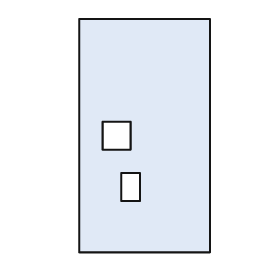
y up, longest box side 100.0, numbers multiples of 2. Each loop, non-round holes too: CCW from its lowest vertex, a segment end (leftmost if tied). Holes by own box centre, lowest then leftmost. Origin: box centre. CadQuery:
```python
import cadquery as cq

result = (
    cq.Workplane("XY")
    .moveTo(-28.0, -50.0)
    .lineTo(28.0, -50.0)
    .lineTo(28.0, 50.0)
    .lineTo(-28.0, 50.0)
    .close()
    .moveTo(-10.0, -28.0)
    .lineTo(-2.0, -28.0)
    .lineTo(-2.0, -16.0)
    .lineTo(-10.0, -16.0)
    .close()
    .moveTo(-18.0, -6.0)
    .lineTo(-6.0, -6.0)
    .lineTo(-6.0, 6.0)
    .lineTo(-18.0, 6.0)
    .close()
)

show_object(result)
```